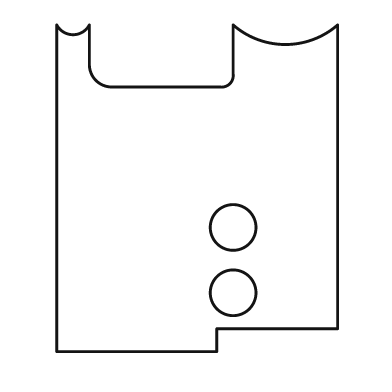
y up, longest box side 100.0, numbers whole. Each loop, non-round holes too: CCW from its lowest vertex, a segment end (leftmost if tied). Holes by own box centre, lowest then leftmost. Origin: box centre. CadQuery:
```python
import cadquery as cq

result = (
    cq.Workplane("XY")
    .moveTo(-43.0, -50.0)
    .lineTo(6.0, -50.0)
    .lineTo(6.0, -43.0)
    .lineTo(43.0, -43.0)
    .lineTo(43.0, 50.0)
    .threePointArc((27.0, 44.0), (11.0, 50.0))
    .lineTo(11.0, 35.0)
    .threePointArc((10.0, 32.0), (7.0, 31.0))
    .lineTo(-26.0, 31.0)
    .threePointArc((-31.0, 33.0), (-33.0, 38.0))
    .lineTo(-33.0, 50.0)
    .threePointArc((-38.0, 47.0), (-43.0, 50.0))
    .close()
    .moveTo(11.0, -32.0)
    .circle(7.0)
    .moveTo(11.0, -12.0)
    .circle(7.0)
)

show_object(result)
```